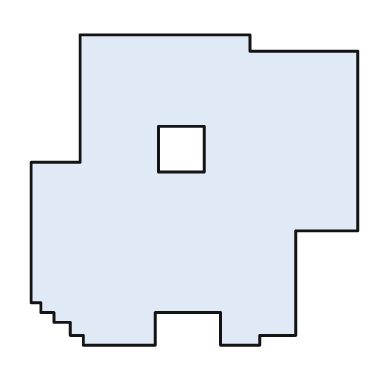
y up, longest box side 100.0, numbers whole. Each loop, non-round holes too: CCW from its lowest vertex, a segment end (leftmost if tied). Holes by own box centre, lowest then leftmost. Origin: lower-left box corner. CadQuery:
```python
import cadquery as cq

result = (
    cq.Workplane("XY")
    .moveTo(16.0, 0.0)
    .lineTo(38.0, 0.0)
    .lineTo(38.0, 10.0)
    .lineTo(58.0, 10.0)
    .lineTo(58.0, 0.0)
    .lineTo(70.0, 0.0)
    .lineTo(70.0, 3.0)
    .lineTo(81.0, 3.0)
    .lineTo(81.0, 35.0)
    .lineTo(100.0, 35.0)
    .lineTo(100.0, 90.0)
    .lineTo(67.0, 90.0)
    .lineTo(67.0, 95.0)
    .lineTo(15.0, 95.0)
    .lineTo(15.0, 56.0)
    .lineTo(0.0, 56.0)
    .lineTo(0.0, 13.0)
    .lineTo(3.0, 13.0)
    .lineTo(3.0, 10.0)
    .lineTo(7.0, 10.0)
    .lineTo(7.0, 7.0)
    .lineTo(12.0, 7.0)
    .lineTo(12.0, 3.0)
    .lineTo(16.0, 3.0)
    .close()
    .moveTo(39.0, 53.0)
    .lineTo(53.0, 53.0)
    .lineTo(53.0, 67.0)
    .lineTo(39.0, 67.0)
    .close()
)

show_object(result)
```